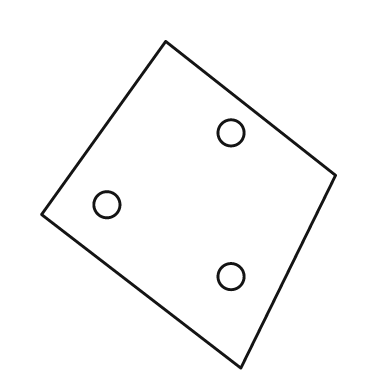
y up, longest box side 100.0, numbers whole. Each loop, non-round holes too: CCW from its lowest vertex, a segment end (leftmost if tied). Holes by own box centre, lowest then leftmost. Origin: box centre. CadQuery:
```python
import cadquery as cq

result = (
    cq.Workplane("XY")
    .moveTo(16.0, -50.0)
    .lineTo(45.0, 9.0)
    .lineTo(-7.0, 50.0)
    .lineTo(-45.0, -3.0)
    .close()
    .moveTo(13.0, -22.0)
    .circle(4.0)
    .moveTo(-25.0, 0.0)
    .circle(4.0)
    .moveTo(13.0, 22.0)
    .circle(4.0)
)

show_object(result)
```